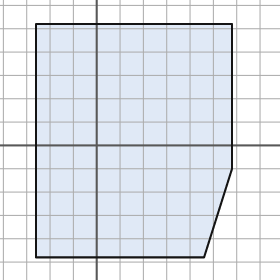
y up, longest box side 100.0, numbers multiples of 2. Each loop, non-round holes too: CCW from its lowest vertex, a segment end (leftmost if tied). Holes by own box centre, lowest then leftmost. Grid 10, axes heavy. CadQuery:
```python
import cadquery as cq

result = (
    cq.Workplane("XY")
    .moveTo(-26.0, -48.0)
    .lineTo(46.0, -48.0)
    .lineTo(58.0, -10.0)
    .lineTo(58.0, 52.0)
    .lineTo(-26.0, 52.0)
    .close()
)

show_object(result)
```